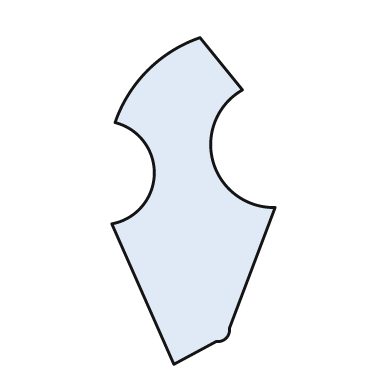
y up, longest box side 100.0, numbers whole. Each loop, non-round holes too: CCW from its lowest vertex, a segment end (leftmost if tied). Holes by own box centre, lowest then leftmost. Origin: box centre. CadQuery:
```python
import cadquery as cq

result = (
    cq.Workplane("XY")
    .moveTo(-6.0, -50.0)
    .lineTo(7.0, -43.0)
    .threePointArc((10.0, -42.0), (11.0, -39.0))
    .lineTo(25.0, -2.0)
    .threePointArc((6.0, 12.0), (15.0, 34.0))
    .lineTo(2.0, 50.0)
    .threePointArc((-14.0, 40.0), (-24.0, 24.0))
    .threePointArc((-12.0, 8.0), (-25.0, -7.0))
    .close()
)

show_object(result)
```